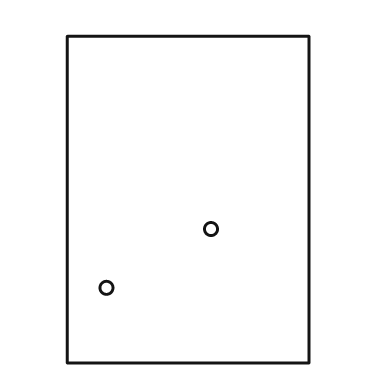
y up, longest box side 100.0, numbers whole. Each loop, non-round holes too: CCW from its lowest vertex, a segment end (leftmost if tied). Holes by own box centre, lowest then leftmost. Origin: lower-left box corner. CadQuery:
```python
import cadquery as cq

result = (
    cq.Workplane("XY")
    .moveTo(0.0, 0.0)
    .lineTo(74.0, 0.0)
    .lineTo(74.0, 100.0)
    .lineTo(0.0, 100.0)
    .close()
    .moveTo(12.0, 23.0)
    .circle(2.0)
    .moveTo(44.0, 41.0)
    .circle(2.0)
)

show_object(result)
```